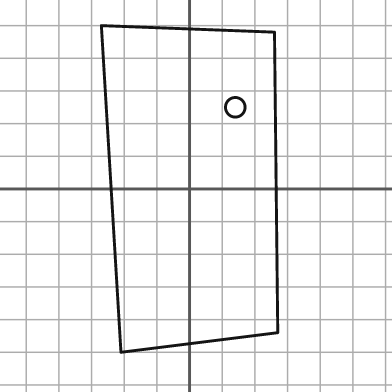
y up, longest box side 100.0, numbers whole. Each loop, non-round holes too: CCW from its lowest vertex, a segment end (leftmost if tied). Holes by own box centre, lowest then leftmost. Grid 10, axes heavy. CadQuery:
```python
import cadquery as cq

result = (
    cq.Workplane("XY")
    .moveTo(-21.0, -50.0)
    .lineTo(27.0, -44.0)
    .lineTo(26.0, 48.0)
    .lineTo(-27.0, 50.0)
    .close()
    .moveTo(14.0, 25.0)
    .circle(3.0)
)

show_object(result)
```